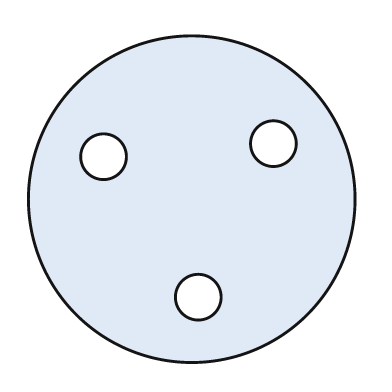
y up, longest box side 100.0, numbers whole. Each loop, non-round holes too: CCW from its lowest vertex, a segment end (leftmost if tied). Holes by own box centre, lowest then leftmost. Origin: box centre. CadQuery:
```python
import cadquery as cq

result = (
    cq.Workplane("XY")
    .moveTo(0.0, 0.0)
    .circle(50.0)
    .moveTo(2.0, -30.0)
    .circle(7.0)
    .moveTo(-27.0, 13.0)
    .circle(7.0)
    .moveTo(25.0, 17.0)
    .circle(7.0)
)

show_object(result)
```